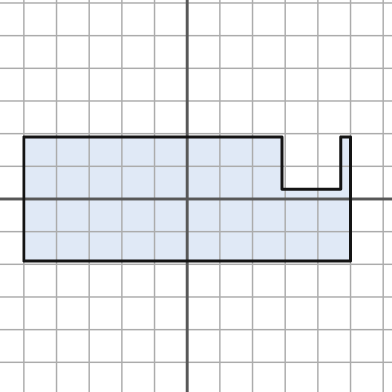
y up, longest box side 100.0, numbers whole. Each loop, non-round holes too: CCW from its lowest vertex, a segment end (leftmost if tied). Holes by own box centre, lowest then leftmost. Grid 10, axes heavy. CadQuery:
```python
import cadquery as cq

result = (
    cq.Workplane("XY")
    .moveTo(-50.0, -19.0)
    .lineTo(50.0, -19.0)
    .lineTo(50.0, 19.0)
    .lineTo(47.0, 19.0)
    .lineTo(47.0, 3.0)
    .lineTo(29.0, 3.0)
    .lineTo(29.0, 19.0)
    .lineTo(-50.0, 19.0)
    .close()
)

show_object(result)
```